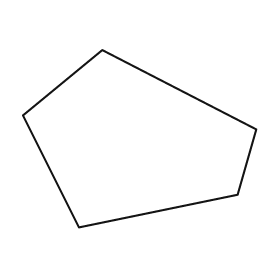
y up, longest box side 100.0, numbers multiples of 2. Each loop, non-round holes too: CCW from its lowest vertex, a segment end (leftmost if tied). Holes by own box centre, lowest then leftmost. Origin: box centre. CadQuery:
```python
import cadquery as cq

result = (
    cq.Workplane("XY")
    .moveTo(-26.0, -38.0)
    .lineTo(42.0, -24.0)
    .lineTo(50.0, 4.0)
    .lineTo(-16.0, 38.0)
    .lineTo(-50.0, 10.0)
    .close()
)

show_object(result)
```